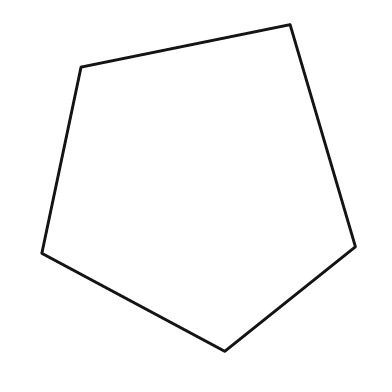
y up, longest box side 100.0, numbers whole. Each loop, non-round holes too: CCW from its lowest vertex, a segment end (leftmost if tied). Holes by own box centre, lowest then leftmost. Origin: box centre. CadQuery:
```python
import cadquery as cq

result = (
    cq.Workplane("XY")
    .moveTo(8.0, -50.0)
    .lineTo(48.0, -18.0)
    .lineTo(28.0, 50.0)
    .lineTo(-36.0, 37.0)
    .lineTo(-48.0, -20.0)
    .close()
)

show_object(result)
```